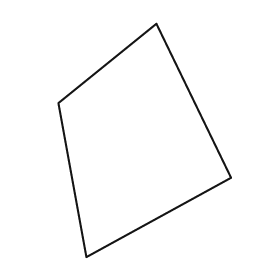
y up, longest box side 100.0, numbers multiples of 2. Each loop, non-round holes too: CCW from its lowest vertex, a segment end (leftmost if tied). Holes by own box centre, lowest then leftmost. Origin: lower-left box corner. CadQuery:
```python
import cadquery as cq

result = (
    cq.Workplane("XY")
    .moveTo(12.0, 0.0)
    .lineTo(74.0, 34.0)
    .lineTo(42.0, 100.0)
    .lineTo(0.0, 66.0)
    .close()
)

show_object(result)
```